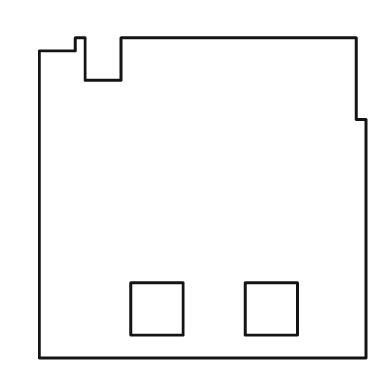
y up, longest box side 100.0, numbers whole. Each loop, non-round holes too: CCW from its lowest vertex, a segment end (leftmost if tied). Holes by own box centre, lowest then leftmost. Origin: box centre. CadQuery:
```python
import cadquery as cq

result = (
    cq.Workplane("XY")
    .moveTo(-50.0, -49.0)
    .lineTo(50.0, -49.0)
    .lineTo(50.0, 24.0)
    .lineTo(47.0, 24.0)
    .lineTo(47.0, 49.0)
    .lineTo(-25.0, 49.0)
    .lineTo(-25.0, 36.0)
    .lineTo(-36.0, 36.0)
    .lineTo(-36.0, 49.0)
    .lineTo(-39.0, 49.0)
    .lineTo(-39.0, 45.0)
    .lineTo(-50.0, 45.0)
    .close()
    .moveTo(-22.0, -42.0)
    .lineTo(-6.0, -42.0)
    .lineTo(-6.0, -26.0)
    .lineTo(-22.0, -26.0)
    .close()
    .moveTo(13.0, -42.0)
    .lineTo(29.0, -42.0)
    .lineTo(29.0, -26.0)
    .lineTo(13.0, -26.0)
    .close()
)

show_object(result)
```